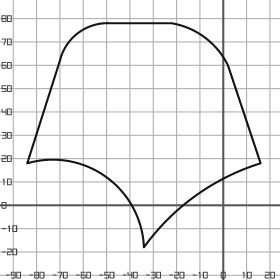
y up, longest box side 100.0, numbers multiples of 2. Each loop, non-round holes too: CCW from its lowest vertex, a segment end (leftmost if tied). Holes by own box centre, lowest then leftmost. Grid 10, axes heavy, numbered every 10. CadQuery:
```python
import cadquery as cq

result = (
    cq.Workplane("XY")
    .moveTo(-34.0, -18.0)
    .threePointArc((-12.0, 4.0), (16.0, 18.0))
    .lineTo(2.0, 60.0)
    .threePointArc((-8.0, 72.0), (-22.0, 78.0))
    .lineTo(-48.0, 78.0)
    .threePointArc((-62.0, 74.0), (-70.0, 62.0))
    .lineTo(-84.0, 18.0)
    .threePointArc((-50.0, 12.0), (-34.0, -18.0))
    .close()
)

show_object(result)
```